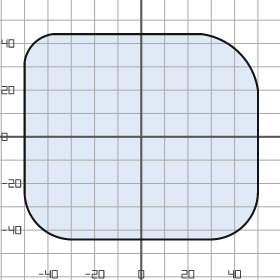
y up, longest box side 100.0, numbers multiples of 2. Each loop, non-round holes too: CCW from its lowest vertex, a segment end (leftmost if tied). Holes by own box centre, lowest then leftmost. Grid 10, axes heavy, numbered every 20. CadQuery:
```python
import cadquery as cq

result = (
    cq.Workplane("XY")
    .moveTo(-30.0, -44.0)
    .lineTo(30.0, -44.0)
    .threePointArc((44.0, -38.0), (50.0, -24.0))
    .lineTo(50.0, 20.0)
    .threePointArc((42.0, 36.0), (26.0, 44.0))
    .lineTo(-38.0, 44.0)
    .threePointArc((-46.0, 40.0), (-50.0, 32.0))
    .lineTo(-50.0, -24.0)
    .threePointArc((-44.0, -38.0), (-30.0, -44.0))
    .close()
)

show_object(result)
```